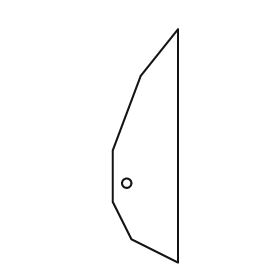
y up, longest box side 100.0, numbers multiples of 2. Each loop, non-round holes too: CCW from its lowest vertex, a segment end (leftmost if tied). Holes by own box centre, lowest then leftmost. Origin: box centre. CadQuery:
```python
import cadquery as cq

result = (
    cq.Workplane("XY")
    .moveTo(14.0, -50.0)
    .lineTo(14.0, 50.0)
    .lineTo(-2.0, 30.0)
    .lineTo(-14.0, -2.0)
    .lineTo(-14.0, -24.0)
    .lineTo(-6.0, -40.0)
    .close()
    .moveTo(-8.0, -16.0)
    .circle(2.0)
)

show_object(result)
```